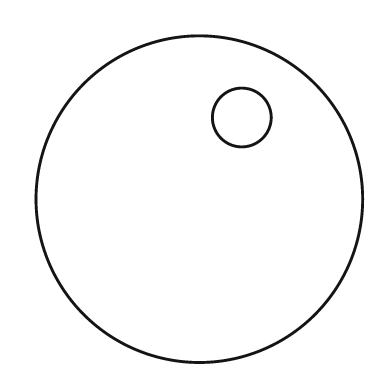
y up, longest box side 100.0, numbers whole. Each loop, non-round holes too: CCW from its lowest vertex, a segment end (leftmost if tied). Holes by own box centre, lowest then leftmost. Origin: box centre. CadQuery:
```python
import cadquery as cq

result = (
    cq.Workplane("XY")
    .moveTo(0.0, 0.0)
    .circle(50.0)
    .moveTo(13.0, 25.0)
    .circle(9.0)
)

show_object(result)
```